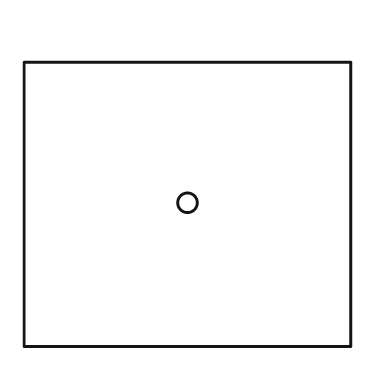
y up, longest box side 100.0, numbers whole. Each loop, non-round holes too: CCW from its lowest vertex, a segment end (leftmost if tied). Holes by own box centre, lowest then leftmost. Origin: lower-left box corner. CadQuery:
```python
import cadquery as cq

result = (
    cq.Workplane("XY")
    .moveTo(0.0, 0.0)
    .lineTo(100.0, 0.0)
    .lineTo(100.0, 87.0)
    .lineTo(0.0, 87.0)
    .close()
    .moveTo(50.0, 44.0)
    .circle(3.0)
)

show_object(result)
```